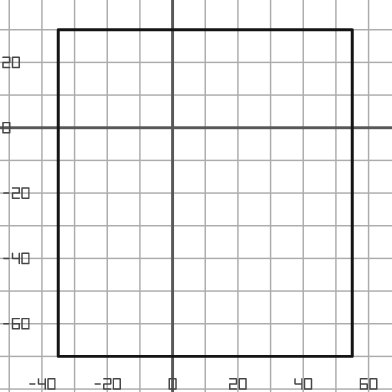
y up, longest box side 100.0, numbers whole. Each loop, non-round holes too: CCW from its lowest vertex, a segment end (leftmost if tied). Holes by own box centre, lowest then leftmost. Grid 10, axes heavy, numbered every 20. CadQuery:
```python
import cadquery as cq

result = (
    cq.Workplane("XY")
    .moveTo(-35.0, -70.0)
    .lineTo(55.0, -70.0)
    .lineTo(55.0, 30.0)
    .lineTo(-35.0, 30.0)
    .close()
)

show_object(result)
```